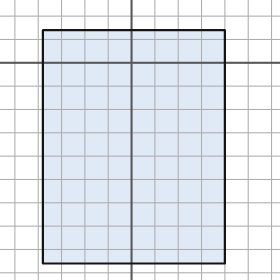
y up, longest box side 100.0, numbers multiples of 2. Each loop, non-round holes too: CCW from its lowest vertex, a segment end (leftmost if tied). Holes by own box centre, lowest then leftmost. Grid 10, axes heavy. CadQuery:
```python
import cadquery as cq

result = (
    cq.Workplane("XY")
    .moveTo(-38.0, -86.0)
    .lineTo(40.0, -86.0)
    .lineTo(40.0, 14.0)
    .lineTo(-38.0, 14.0)
    .close()
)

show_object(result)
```